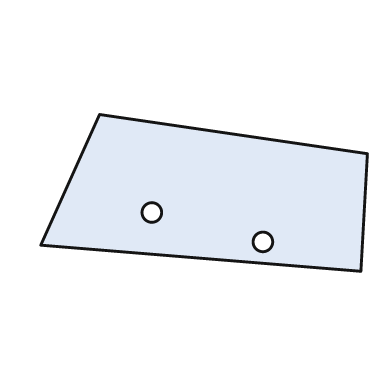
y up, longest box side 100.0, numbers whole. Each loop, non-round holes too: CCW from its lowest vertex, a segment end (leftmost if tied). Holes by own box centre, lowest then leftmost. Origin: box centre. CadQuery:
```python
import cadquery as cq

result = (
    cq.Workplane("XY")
    .moveTo(48.0, -24.0)
    .lineTo(50.0, 12.0)
    .lineTo(-32.0, 24.0)
    .lineTo(-50.0, -16.0)
    .close()
    .moveTo(18.0, -15.0)
    .circle(3.0)
    .moveTo(-16.0, -6.0)
    .circle(3.0)
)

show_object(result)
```